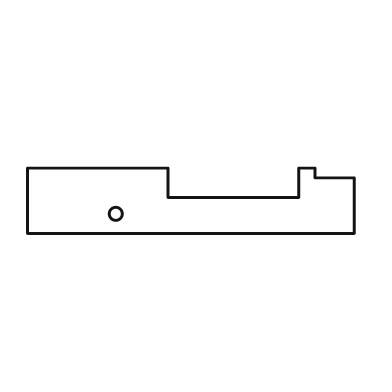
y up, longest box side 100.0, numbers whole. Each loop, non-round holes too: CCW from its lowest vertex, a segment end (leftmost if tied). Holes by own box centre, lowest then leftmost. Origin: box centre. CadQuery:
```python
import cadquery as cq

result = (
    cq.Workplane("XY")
    .moveTo(-50.0, -10.0)
    .lineTo(50.0, -10.0)
    .lineTo(50.0, 7.0)
    .lineTo(38.0, 7.0)
    .lineTo(38.0, 10.0)
    .lineTo(33.0, 10.0)
    .lineTo(33.0, 1.0)
    .lineTo(-7.0, 1.0)
    .lineTo(-7.0, 10.0)
    .lineTo(-50.0, 10.0)
    .close()
    .moveTo(-23.0, -4.0)
    .circle(2.0)
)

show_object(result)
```